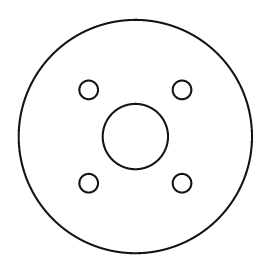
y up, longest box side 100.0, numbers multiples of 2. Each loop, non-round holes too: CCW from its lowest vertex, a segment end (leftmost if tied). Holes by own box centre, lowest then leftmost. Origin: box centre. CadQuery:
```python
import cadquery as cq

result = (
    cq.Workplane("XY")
    .moveTo(0.0, 0.0)
    .circle(50.0)
    .moveTo(-20.0, -20.0)
    .circle(4.0)
    .moveTo(20.0, -20.0)
    .circle(4.0)
    .moveTo(0.0, 0.0)
    .circle(14.0)
    .moveTo(-20.0, 20.0)
    .circle(4.0)
    .moveTo(20.0, 20.0)
    .circle(4.0)
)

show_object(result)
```